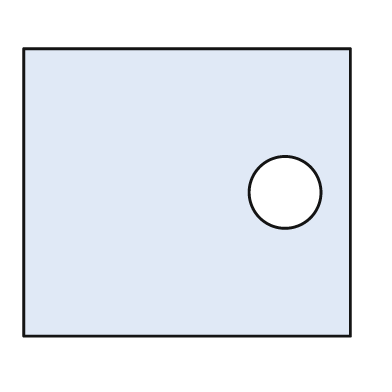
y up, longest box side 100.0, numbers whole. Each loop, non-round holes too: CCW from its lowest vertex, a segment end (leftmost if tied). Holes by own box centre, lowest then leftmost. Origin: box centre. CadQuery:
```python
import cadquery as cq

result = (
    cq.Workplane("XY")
    .moveTo(-50.0, -44.0)
    .lineTo(50.0, -44.0)
    .lineTo(50.0, 44.0)
    .lineTo(-50.0, 44.0)
    .close()
    .moveTo(30.0, 0.0)
    .circle(11.0)
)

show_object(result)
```